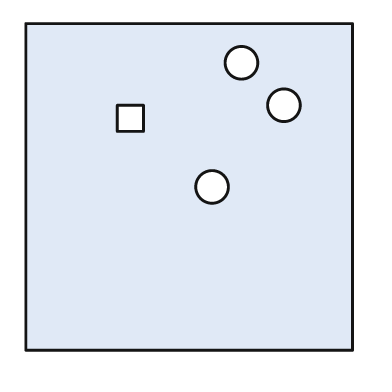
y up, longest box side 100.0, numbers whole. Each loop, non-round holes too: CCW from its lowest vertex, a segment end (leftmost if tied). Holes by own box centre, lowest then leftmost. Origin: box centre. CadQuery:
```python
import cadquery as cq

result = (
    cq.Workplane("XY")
    .moveTo(-50.0, -50.0)
    .lineTo(50.0, -50.0)
    .lineTo(50.0, 50.0)
    .lineTo(-50.0, 50.0)
    .close()
    .moveTo(7.0, 0.0)
    .circle(5.0)
    .moveTo(-22.0, 17.0)
    .lineTo(-14.0, 17.0)
    .lineTo(-14.0, 25.0)
    .lineTo(-22.0, 25.0)
    .close()
    .moveTo(29.0, 25.0)
    .circle(5.0)
    .moveTo(16.0, 38.0)
    .circle(5.0)
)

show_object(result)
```